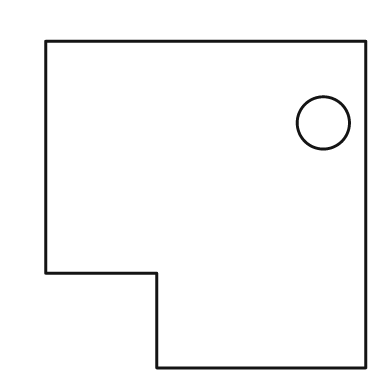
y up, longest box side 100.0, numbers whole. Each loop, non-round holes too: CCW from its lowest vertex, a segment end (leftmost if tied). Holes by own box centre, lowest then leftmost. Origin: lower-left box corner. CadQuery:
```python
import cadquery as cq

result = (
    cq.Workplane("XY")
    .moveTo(34.0, 0.0)
    .lineTo(98.0, 0.0)
    .lineTo(98.0, 100.0)
    .lineTo(0.0, 100.0)
    .lineTo(0.0, 29.0)
    .lineTo(34.0, 29.0)
    .close()
    .moveTo(85.0, 75.0)
    .circle(8.0)
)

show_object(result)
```